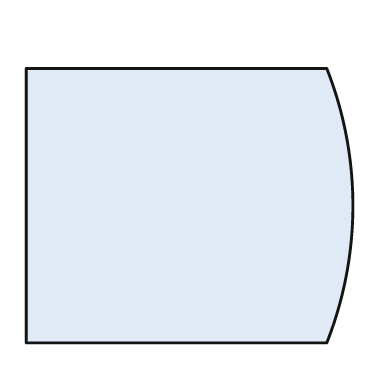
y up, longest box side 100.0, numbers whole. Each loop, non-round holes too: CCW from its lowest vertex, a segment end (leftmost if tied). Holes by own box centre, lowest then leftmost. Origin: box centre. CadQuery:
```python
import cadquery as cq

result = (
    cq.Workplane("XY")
    .moveTo(-50.0, -42.0)
    .lineTo(42.0, -42.0)
    .threePointArc((50.0, 0.0), (42.0, 42.0))
    .lineTo(-50.0, 42.0)
    .close()
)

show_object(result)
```